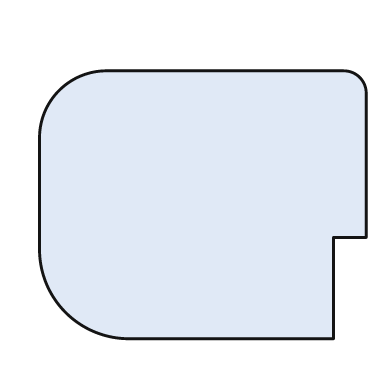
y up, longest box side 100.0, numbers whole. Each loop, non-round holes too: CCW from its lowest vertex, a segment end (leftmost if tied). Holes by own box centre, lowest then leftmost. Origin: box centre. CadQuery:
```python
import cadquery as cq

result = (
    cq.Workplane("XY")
    .moveTo(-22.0, -41.0)
    .lineTo(40.0, -41.0)
    .lineTo(40.0, -10.0)
    .lineTo(50.0, -10.0)
    .lineTo(50.0, 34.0)
    .threePointArc((48.0, 39.0), (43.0, 41.0))
    .lineTo(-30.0, 41.0)
    .threePointArc((-44.0, 35.0), (-50.0, 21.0))
    .lineTo(-50.0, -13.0)
    .threePointArc((-42.0, -33.0), (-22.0, -41.0))
    .close()
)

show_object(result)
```